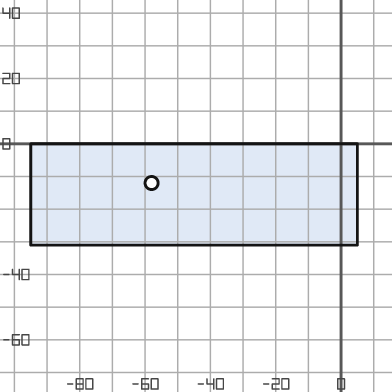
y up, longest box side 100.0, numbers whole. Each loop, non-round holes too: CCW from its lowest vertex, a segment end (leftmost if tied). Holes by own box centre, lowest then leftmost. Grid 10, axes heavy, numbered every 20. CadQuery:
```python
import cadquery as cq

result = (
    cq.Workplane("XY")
    .moveTo(-95.0, -31.0)
    .lineTo(5.0, -31.0)
    .lineTo(5.0, 0.0)
    .lineTo(-95.0, 0.0)
    .close()
    .moveTo(-58.0, -12.0)
    .circle(2.0)
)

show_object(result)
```